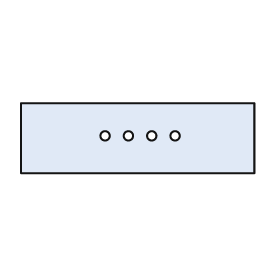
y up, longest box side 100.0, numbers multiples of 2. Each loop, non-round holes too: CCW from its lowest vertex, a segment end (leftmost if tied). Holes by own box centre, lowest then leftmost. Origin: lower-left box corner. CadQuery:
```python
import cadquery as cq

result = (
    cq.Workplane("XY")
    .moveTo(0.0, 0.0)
    .lineTo(100.0, 0.0)
    .lineTo(100.0, 30.0)
    .lineTo(0.0, 30.0)
    .close()
    .moveTo(36.0, 16.0)
    .circle(2.0)
    .moveTo(46.0, 16.0)
    .circle(2.0)
    .moveTo(56.0, 16.0)
    .circle(2.0)
    .moveTo(66.0, 16.0)
    .circle(2.0)
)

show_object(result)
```